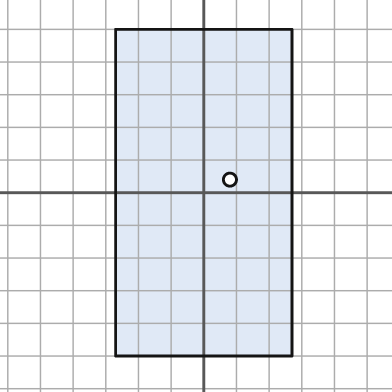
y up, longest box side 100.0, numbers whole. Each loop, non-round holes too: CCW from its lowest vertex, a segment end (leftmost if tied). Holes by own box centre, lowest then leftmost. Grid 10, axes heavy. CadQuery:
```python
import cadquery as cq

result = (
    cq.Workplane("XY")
    .moveTo(-27.0, -50.0)
    .lineTo(27.0, -50.0)
    .lineTo(27.0, 50.0)
    .lineTo(-27.0, 50.0)
    .close()
    .moveTo(8.0, 4.0)
    .circle(2.0)
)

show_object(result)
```